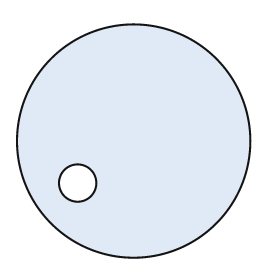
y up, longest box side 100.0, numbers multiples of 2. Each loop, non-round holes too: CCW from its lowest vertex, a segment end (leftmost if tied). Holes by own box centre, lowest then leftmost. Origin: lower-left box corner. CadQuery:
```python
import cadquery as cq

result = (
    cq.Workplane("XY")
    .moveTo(50.0, 50.0)
    .circle(50.0)
    .moveTo(26.0, 32.0)
    .circle(8.0)
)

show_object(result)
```